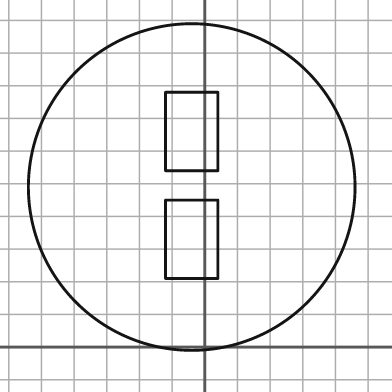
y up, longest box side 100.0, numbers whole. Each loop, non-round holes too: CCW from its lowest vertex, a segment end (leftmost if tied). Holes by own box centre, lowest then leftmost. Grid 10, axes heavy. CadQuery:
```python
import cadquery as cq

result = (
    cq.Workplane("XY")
    .moveTo(-4.0, 49.0)
    .circle(50.0)
    .moveTo(-12.0, 21.0)
    .lineTo(4.0, 21.0)
    .lineTo(4.0, 45.0)
    .lineTo(-12.0, 45.0)
    .close()
    .moveTo(-12.0, 54.0)
    .lineTo(4.0, 54.0)
    .lineTo(4.0, 78.0)
    .lineTo(-12.0, 78.0)
    .close()
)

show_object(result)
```